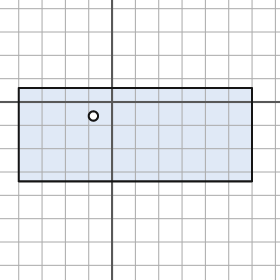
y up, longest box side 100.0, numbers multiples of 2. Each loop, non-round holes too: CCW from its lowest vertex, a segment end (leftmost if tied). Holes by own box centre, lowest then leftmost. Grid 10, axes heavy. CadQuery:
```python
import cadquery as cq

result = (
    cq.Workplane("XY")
    .moveTo(-40.0, -34.0)
    .lineTo(60.0, -34.0)
    .lineTo(60.0, 6.0)
    .lineTo(-40.0, 6.0)
    .close()
    .moveTo(-8.0, -6.0)
    .circle(2.0)
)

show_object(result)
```